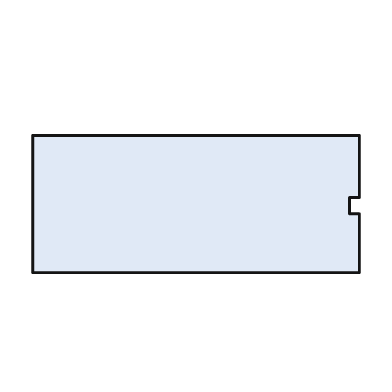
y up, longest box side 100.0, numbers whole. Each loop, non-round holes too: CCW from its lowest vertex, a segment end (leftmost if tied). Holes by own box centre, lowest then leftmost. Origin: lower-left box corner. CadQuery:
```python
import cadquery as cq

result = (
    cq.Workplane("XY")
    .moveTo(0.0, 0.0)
    .lineTo(100.0, 0.0)
    .lineTo(100.0, 18.0)
    .lineTo(97.0, 18.0)
    .lineTo(97.0, 23.0)
    .lineTo(100.0, 23.0)
    .lineTo(100.0, 42.0)
    .lineTo(0.0, 42.0)
    .close()
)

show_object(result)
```